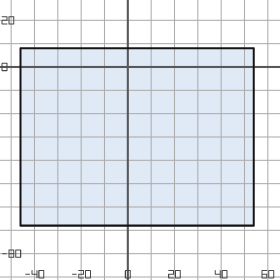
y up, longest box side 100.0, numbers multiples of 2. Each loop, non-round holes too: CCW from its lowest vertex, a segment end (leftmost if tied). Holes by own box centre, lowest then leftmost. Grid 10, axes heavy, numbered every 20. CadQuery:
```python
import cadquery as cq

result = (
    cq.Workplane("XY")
    .moveTo(-46.0, -68.0)
    .lineTo(54.0, -68.0)
    .lineTo(54.0, 8.0)
    .lineTo(-46.0, 8.0)
    .close()
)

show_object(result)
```